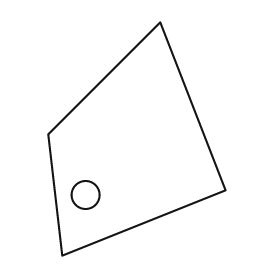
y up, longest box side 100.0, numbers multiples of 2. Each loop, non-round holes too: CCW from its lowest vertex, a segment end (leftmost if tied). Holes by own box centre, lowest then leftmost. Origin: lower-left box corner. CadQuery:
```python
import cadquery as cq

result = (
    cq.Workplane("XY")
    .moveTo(6.0, 0.0)
    .lineTo(76.0, 28.0)
    .lineTo(48.0, 100.0)
    .lineTo(0.0, 52.0)
    .close()
    .moveTo(16.0, 26.0)
    .circle(6.0)
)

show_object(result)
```